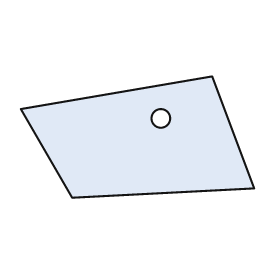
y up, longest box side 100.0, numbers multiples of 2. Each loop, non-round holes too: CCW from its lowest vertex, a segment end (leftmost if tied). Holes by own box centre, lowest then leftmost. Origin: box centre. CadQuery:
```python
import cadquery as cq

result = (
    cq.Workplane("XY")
    .moveTo(-28.0, -26.0)
    .lineTo(50.0, -22.0)
    .lineTo(32.0, 26.0)
    .lineTo(-50.0, 12.0)
    .close()
    .moveTo(10.0, 8.0)
    .circle(4.0)
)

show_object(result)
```